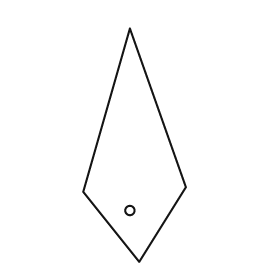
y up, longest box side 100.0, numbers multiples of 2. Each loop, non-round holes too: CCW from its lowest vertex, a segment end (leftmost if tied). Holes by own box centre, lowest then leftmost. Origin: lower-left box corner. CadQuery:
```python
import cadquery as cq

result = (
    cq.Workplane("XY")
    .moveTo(24.0, 0.0)
    .lineTo(44.0, 32.0)
    .lineTo(20.0, 100.0)
    .lineTo(0.0, 30.0)
    .close()
    .moveTo(20.0, 22.0)
    .circle(2.0)
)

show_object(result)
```